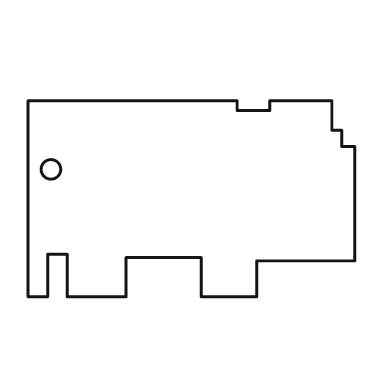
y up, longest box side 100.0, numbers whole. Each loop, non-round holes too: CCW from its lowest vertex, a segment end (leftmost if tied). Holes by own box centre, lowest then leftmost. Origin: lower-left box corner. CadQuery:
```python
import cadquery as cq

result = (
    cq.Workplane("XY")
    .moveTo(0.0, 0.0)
    .lineTo(6.0, 0.0)
    .lineTo(6.0, 13.0)
    .lineTo(12.0, 13.0)
    .lineTo(12.0, 0.0)
    .lineTo(30.0, 0.0)
    .lineTo(30.0, 12.0)
    .lineTo(53.0, 12.0)
    .lineTo(53.0, 0.0)
    .lineTo(70.0, 0.0)
    .lineTo(70.0, 11.0)
    .lineTo(100.0, 11.0)
    .lineTo(100.0, 46.0)
    .lineTo(96.0, 46.0)
    .lineTo(96.0, 51.0)
    .lineTo(93.0, 51.0)
    .lineTo(93.0, 60.0)
    .lineTo(74.0, 60.0)
    .lineTo(74.0, 57.0)
    .lineTo(64.0, 57.0)
    .lineTo(64.0, 60.0)
    .lineTo(0.0, 60.0)
    .close()
    .moveTo(7.0, 39.0)
    .circle(3.0)
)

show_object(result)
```